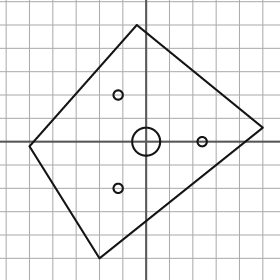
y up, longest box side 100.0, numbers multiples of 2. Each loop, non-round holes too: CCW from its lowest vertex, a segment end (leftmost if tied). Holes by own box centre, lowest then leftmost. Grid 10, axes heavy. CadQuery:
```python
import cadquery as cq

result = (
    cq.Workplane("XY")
    .moveTo(-20.0, -50.0)
    .lineTo(50.0, 6.0)
    .lineTo(-4.0, 50.0)
    .lineTo(-50.0, -2.0)
    .close()
    .moveTo(-12.0, -20.0)
    .circle(2.0)
    .moveTo(0.0, 0.0)
    .circle(6.0)
    .moveTo(24.0, 0.0)
    .circle(2.0)
    .moveTo(-12.0, 20.0)
    .circle(2.0)
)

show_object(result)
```